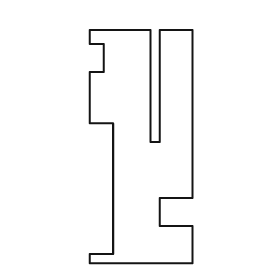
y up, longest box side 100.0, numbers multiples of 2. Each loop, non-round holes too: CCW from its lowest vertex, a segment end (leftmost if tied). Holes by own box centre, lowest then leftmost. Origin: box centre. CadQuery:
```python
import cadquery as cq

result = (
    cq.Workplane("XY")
    .moveTo(-22.0, -50.0)
    .lineTo(22.0, -50.0)
    .lineTo(22.0, -34.0)
    .lineTo(8.0, -34.0)
    .lineTo(8.0, -22.0)
    .lineTo(22.0, -22.0)
    .lineTo(22.0, 50.0)
    .lineTo(8.0, 50.0)
    .lineTo(8.0, 2.0)
    .lineTo(4.0, 2.0)
    .lineTo(4.0, 50.0)
    .lineTo(-22.0, 50.0)
    .lineTo(-22.0, 44.0)
    .lineTo(-16.0, 44.0)
    .lineTo(-16.0, 32.0)
    .lineTo(-22.0, 32.0)
    .lineTo(-22.0, 10.0)
    .lineTo(-12.0, 10.0)
    .lineTo(-12.0, -46.0)
    .lineTo(-22.0, -46.0)
    .close()
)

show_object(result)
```